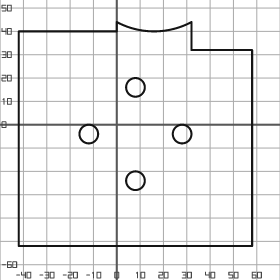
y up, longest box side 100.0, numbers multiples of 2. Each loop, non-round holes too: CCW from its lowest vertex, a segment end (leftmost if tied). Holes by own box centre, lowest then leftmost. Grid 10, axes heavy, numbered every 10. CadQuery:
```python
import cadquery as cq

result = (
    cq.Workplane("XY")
    .moveTo(-42.0, -52.0)
    .lineTo(58.0, -52.0)
    .lineTo(58.0, 32.0)
    .lineTo(32.0, 32.0)
    .lineTo(32.0, 44.0)
    .threePointArc((16.0, 40.0), (0.0, 44.0))
    .lineTo(0.0, 40.0)
    .lineTo(-42.0, 40.0)
    .close()
    .moveTo(8.0, -24.0)
    .circle(4.0)
    .moveTo(-12.0, -4.0)
    .circle(4.0)
    .moveTo(28.0, -4.0)
    .circle(4.0)
    .moveTo(8.0, 16.0)
    .circle(4.0)
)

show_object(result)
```